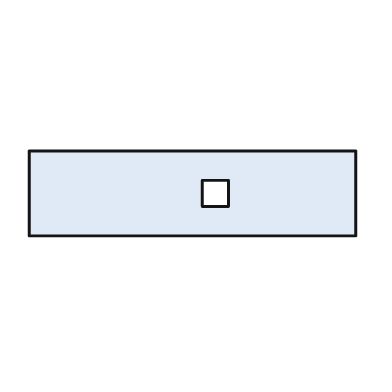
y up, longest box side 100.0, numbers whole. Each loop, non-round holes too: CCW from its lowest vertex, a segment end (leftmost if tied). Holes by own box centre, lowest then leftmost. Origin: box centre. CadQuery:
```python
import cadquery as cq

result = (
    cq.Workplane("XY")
    .moveTo(-50.0, -13.0)
    .lineTo(50.0, -13.0)
    .lineTo(50.0, 13.0)
    .lineTo(-50.0, 13.0)
    .close()
    .moveTo(3.0, -4.0)
    .lineTo(11.0, -4.0)
    .lineTo(11.0, 4.0)
    .lineTo(3.0, 4.0)
    .close()
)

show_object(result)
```